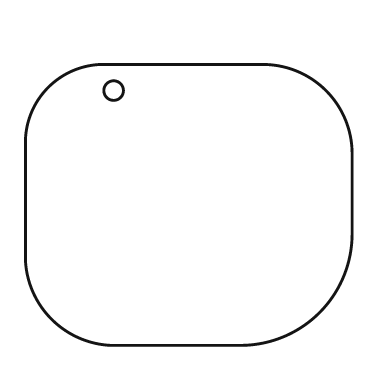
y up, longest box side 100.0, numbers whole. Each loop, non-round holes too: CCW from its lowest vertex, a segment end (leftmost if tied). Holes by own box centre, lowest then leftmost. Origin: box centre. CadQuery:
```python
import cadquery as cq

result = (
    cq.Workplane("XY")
    .moveTo(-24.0, -43.0)
    .lineTo(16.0, -43.0)
    .threePointArc((40.0, -33.0), (50.0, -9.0))
    .lineTo(50.0, 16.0)
    .threePointArc((42.0, 35.0), (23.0, 43.0))
    .lineTo(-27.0, 43.0)
    .threePointArc((-43.0, 36.0), (-50.0, 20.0))
    .lineTo(-50.0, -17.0)
    .threePointArc((-42.0, -35.0), (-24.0, -43.0))
    .close()
    .moveTo(-23.0, 35.0)
    .circle(3.0)
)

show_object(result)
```